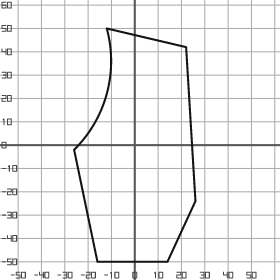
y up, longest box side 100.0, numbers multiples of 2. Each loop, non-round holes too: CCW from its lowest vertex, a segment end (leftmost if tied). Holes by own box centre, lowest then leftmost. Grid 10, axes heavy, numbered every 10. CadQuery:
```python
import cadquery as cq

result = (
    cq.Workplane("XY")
    .moveTo(-16.0, -50.0)
    .lineTo(14.0, -50.0)
    .lineTo(26.0, -24.0)
    .lineTo(22.0, 42.0)
    .lineTo(-12.0, 50.0)
    .threePointArc((-12.0, 22.0), (-26.0, -2.0))
    .close()
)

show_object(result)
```